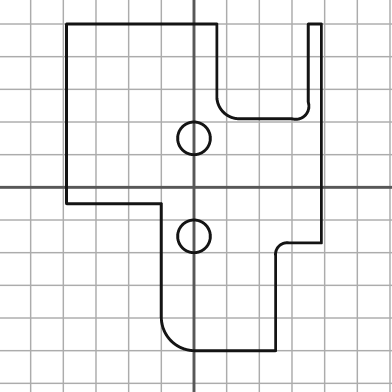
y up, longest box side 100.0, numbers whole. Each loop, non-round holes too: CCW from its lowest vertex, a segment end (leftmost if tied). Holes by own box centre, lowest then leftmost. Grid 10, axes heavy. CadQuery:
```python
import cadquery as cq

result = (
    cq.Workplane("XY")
    .moveTo(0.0, -50.0)
    .lineTo(25.0, -50.0)
    .lineTo(25.0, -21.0)
    .threePointArc((26.0, -18.0), (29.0, -17.0))
    .lineTo(39.0, -17.0)
    .lineTo(39.0, 50.0)
    .lineTo(35.0, 50.0)
    .lineTo(35.0, 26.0)
    .threePointArc((34.0, 22.0), (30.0, 21.0))
    .lineTo(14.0, 21.0)
    .threePointArc((9.0, 23.0), (7.0, 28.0))
    .lineTo(7.0, 50.0)
    .lineTo(-39.0, 50.0)
    .lineTo(-39.0, -5.0)
    .lineTo(-10.0, -5.0)
    .lineTo(-10.0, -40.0)
    .threePointArc((-7.0, -47.0), (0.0, -50.0))
    .close()
    .moveTo(0.0, -15.0)
    .circle(5.0)
    .moveTo(0.0, 15.0)
    .circle(5.0)
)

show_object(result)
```